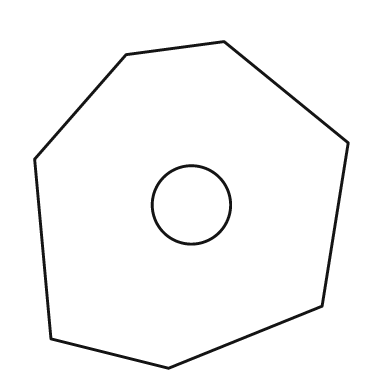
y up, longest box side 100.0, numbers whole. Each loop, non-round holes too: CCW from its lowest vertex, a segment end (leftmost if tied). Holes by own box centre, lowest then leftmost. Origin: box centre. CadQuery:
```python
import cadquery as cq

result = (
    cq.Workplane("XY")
    .moveTo(-7.0, -50.0)
    .lineTo(40.0, -31.0)
    .lineTo(48.0, 19.0)
    .lineTo(10.0, 50.0)
    .lineTo(-20.0, 46.0)
    .lineTo(-48.0, 14.0)
    .lineTo(-43.0, -41.0)
    .close()
    .moveTo(0.0, 0.0)
    .circle(12.0)
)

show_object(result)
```